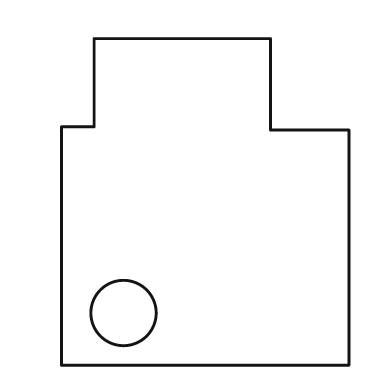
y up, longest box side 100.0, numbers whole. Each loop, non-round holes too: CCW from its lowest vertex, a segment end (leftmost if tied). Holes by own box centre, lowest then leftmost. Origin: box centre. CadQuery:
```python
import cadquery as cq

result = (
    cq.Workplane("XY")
    .moveTo(-44.0, -50.0)
    .lineTo(44.0, -50.0)
    .lineTo(44.0, 22.0)
    .lineTo(20.0, 22.0)
    .lineTo(20.0, 50.0)
    .lineTo(-34.0, 50.0)
    .lineTo(-34.0, 23.0)
    .lineTo(-44.0, 23.0)
    .close()
    .moveTo(-25.0, -34.0)
    .circle(10.0)
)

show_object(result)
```